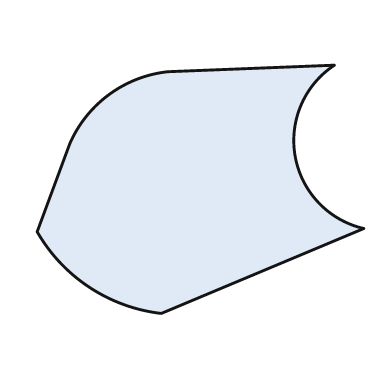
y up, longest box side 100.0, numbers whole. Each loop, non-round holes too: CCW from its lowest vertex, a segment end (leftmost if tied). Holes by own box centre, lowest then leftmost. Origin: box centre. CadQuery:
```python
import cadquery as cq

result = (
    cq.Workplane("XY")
    .moveTo(-12.0, -38.0)
    .lineTo(50.0, -12.0)
    .threePointArc((29.0, 10.0), (41.0, 38.0))
    .lineTo(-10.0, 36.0)
    .threePointArc((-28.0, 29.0), (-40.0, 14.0))
    .lineTo(-50.0, -13.0)
    .threePointArc((-34.0, -30.0), (-12.0, -38.0))
    .close()
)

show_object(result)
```